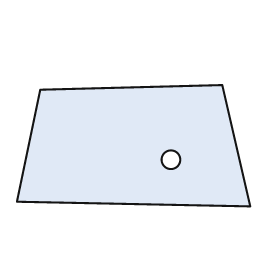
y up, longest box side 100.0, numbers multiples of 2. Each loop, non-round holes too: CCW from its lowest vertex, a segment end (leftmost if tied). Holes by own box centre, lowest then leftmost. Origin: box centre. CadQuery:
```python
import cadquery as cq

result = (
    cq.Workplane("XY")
    .moveTo(50.0, -26.0)
    .lineTo(38.0, 26.0)
    .lineTo(-40.0, 24.0)
    .lineTo(-50.0, -24.0)
    .close()
    .moveTo(16.0, -6.0)
    .circle(4.0)
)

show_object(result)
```